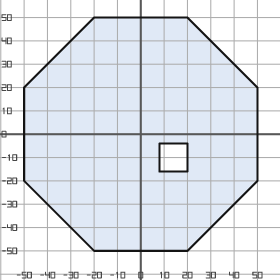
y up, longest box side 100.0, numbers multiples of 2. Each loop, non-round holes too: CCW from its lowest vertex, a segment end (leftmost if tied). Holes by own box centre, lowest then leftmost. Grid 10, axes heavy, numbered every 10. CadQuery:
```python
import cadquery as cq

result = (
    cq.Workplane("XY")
    .moveTo(-20.0, -50.0)
    .lineTo(20.0, -50.0)
    .lineTo(50.0, -20.0)
    .lineTo(50.0, 20.0)
    .lineTo(20.0, 50.0)
    .lineTo(-20.0, 50.0)
    .lineTo(-50.0, 20.0)
    .lineTo(-50.0, -20.0)
    .close()
    .moveTo(8.0, -16.0)
    .lineTo(20.0, -16.0)
    .lineTo(20.0, -4.0)
    .lineTo(8.0, -4.0)
    .close()
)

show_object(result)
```